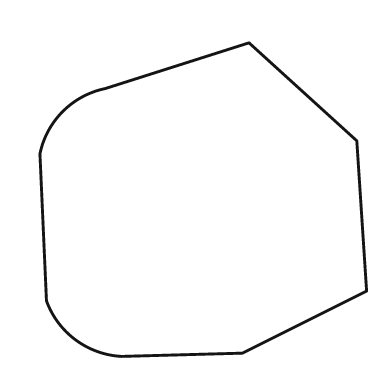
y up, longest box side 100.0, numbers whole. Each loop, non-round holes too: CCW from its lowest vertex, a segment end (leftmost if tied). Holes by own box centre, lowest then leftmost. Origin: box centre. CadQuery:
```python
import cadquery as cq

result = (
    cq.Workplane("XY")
    .moveTo(-25.0, -48.0)
    .lineTo(12.0, -47.0)
    .lineTo(50.0, -28.0)
    .lineTo(47.0, 18.0)
    .lineTo(14.0, 48.0)
    .lineTo(-30.0, 34.0)
    .threePointArc((-43.0, 27.0), (-50.0, 14.0))
    .lineTo(-48.0, -31.0)
    .threePointArc((-39.0, -43.0), (-25.0, -48.0))
    .close()
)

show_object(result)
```